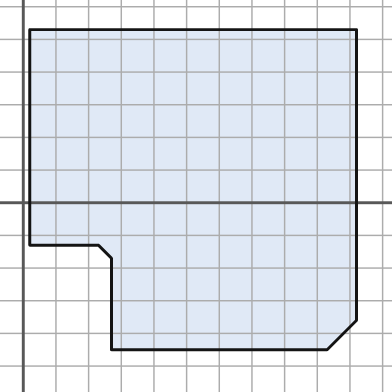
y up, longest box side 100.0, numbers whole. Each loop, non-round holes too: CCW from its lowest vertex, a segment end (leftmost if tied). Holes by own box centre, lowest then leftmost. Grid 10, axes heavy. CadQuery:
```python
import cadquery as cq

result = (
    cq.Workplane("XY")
    .moveTo(27.0, -45.0)
    .lineTo(93.0, -45.0)
    .lineTo(102.0, -36.0)
    .lineTo(102.0, 53.0)
    .lineTo(2.0, 53.0)
    .lineTo(2.0, -13.0)
    .lineTo(23.0, -13.0)
    .lineTo(27.0, -17.0)
    .close()
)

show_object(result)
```